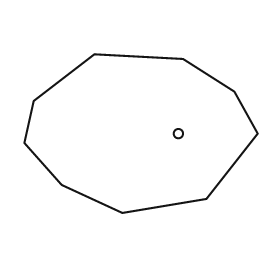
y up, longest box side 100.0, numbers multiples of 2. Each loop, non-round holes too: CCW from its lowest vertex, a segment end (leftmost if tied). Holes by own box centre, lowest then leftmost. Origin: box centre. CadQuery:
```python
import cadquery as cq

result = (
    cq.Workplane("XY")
    .moveTo(-8.0, -34.0)
    .lineTo(28.0, -28.0)
    .lineTo(50.0, 0.0)
    .lineTo(40.0, 18.0)
    .lineTo(18.0, 32.0)
    .lineTo(-20.0, 34.0)
    .lineTo(-46.0, 14.0)
    .lineTo(-50.0, -4.0)
    .lineTo(-34.0, -22.0)
    .close()
    .moveTo(16.0, 0.0)
    .circle(2.0)
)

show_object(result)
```